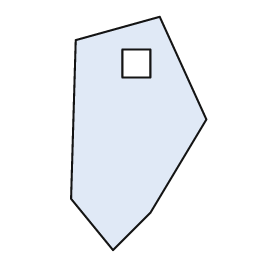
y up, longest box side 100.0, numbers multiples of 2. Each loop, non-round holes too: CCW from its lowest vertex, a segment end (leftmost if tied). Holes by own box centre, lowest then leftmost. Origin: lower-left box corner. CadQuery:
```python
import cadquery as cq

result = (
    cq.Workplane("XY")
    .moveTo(18.0, 0.0)
    .lineTo(34.0, 16.0)
    .lineTo(58.0, 56.0)
    .lineTo(38.0, 100.0)
    .lineTo(2.0, 90.0)
    .lineTo(0.0, 22.0)
    .close()
    .moveTo(22.0, 74.0)
    .lineTo(34.0, 74.0)
    .lineTo(34.0, 86.0)
    .lineTo(22.0, 86.0)
    .close()
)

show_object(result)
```